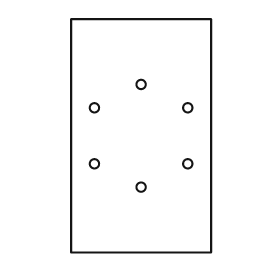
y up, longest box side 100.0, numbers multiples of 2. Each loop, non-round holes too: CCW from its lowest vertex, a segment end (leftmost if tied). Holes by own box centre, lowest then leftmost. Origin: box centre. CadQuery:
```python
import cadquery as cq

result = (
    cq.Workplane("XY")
    .moveTo(-30.0, -50.0)
    .lineTo(30.0, -50.0)
    .lineTo(30.0, 50.0)
    .lineTo(-30.0, 50.0)
    .close()
    .moveTo(0.0, -22.0)
    .circle(2.0)
    .moveTo(-20.0, -12.0)
    .circle(2.0)
    .moveTo(20.0, -12.0)
    .circle(2.0)
    .moveTo(-20.0, 12.0)
    .circle(2.0)
    .moveTo(20.0, 12.0)
    .circle(2.0)
    .moveTo(0.0, 22.0)
    .circle(2.0)
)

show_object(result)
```